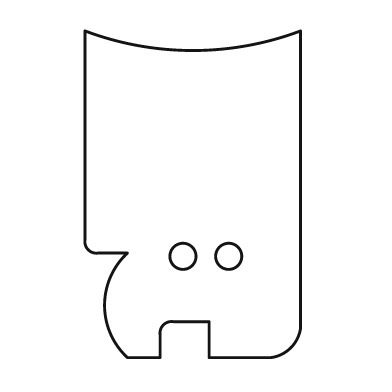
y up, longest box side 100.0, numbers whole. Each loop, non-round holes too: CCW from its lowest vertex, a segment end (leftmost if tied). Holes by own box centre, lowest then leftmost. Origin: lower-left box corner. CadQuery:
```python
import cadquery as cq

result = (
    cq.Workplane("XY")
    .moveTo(13.0, 0.0)
    .lineTo(23.0, 0.0)
    .lineTo(23.0, 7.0)
    .threePointArc((24.0, 10.0), (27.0, 11.0))
    .lineTo(38.0, 11.0)
    .lineTo(38.0, 0.0)
    .lineTo(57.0, 0.0)
    .threePointArc((63.0, 3.0), (66.0, 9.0))
    .lineTo(66.0, 100.0)
    .threePointArc((33.0, 94.0), (0.0, 100.0))
    .lineTo(0.0, 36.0)
    .threePointArc((1.0, 33.0), (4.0, 32.0))
    .lineTo(13.0, 32.0)
    .threePointArc((6.0, 16.0), (13.0, 0.0))
    .close()
    .moveTo(30.0, 31.0)
    .circle(4.0)
    .moveTo(44.0, 31.0)
    .circle(4.0)
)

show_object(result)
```